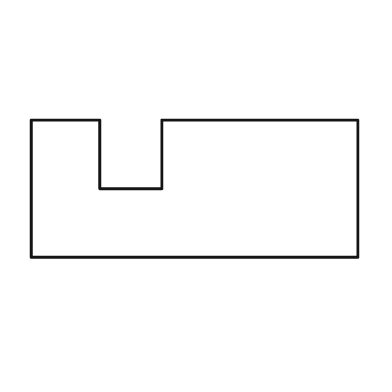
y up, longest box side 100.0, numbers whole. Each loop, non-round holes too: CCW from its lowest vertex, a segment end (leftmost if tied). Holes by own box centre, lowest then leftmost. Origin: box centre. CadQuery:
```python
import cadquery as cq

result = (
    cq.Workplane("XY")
    .moveTo(-50.0, -21.0)
    .lineTo(50.0, -21.0)
    .lineTo(50.0, 21.0)
    .lineTo(-10.0, 21.0)
    .lineTo(-10.0, 0.0)
    .lineTo(-29.0, 0.0)
    .lineTo(-29.0, 21.0)
    .lineTo(-50.0, 21.0)
    .close()
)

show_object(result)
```